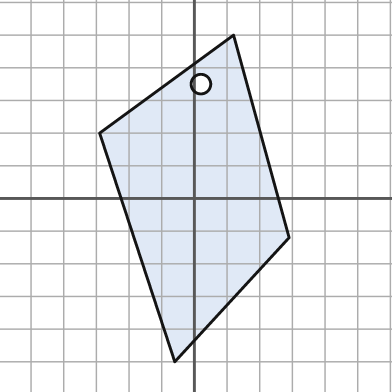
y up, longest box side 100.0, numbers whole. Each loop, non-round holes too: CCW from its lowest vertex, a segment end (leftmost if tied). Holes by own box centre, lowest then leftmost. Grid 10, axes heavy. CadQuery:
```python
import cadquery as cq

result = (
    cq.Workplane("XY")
    .moveTo(-6.0, -50.0)
    .lineTo(29.0, -12.0)
    .lineTo(12.0, 50.0)
    .lineTo(-29.0, 20.0)
    .close()
    .moveTo(2.0, 35.0)
    .circle(3.0)
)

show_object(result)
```